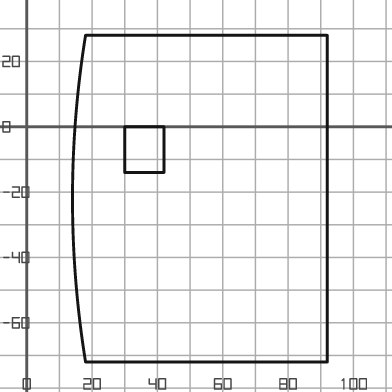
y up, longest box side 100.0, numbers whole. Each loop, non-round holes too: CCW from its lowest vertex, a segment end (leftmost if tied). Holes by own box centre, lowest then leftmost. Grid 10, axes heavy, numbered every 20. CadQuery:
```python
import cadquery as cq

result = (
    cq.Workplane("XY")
    .moveTo(18.0, -72.0)
    .lineTo(92.0, -72.0)
    .lineTo(92.0, 28.0)
    .lineTo(18.0, 28.0)
    .threePointArc((14.0, -22.0), (18.0, -72.0))
    .close()
    .moveTo(30.0, -14.0)
    .lineTo(42.0, -14.0)
    .lineTo(42.0, 0.0)
    .lineTo(30.0, 0.0)
    .close()
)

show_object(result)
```